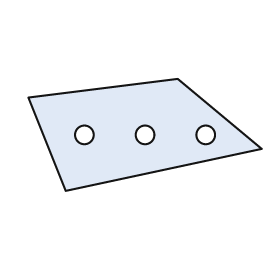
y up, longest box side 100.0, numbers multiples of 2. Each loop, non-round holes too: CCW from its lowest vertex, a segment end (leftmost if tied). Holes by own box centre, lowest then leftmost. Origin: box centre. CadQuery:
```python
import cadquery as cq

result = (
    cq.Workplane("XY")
    .moveTo(-34.0, -24.0)
    .lineTo(50.0, -6.0)
    .lineTo(14.0, 24.0)
    .lineTo(-50.0, 16.0)
    .close()
    .moveTo(-26.0, 0.0)
    .circle(4.0)
    .moveTo(0.0, 0.0)
    .circle(4.0)
    .moveTo(26.0, 0.0)
    .circle(4.0)
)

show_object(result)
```